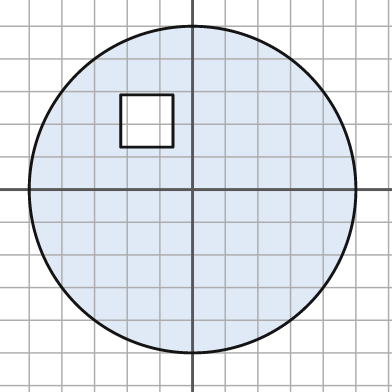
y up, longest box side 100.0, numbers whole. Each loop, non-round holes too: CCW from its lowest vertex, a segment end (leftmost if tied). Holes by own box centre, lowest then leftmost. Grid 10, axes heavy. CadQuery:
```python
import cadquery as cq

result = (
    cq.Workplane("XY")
    .moveTo(0.0, 0.0)
    .circle(50.0)
    .moveTo(-22.0, 13.0)
    .lineTo(-6.0, 13.0)
    .lineTo(-6.0, 29.0)
    .lineTo(-22.0, 29.0)
    .close()
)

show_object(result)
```